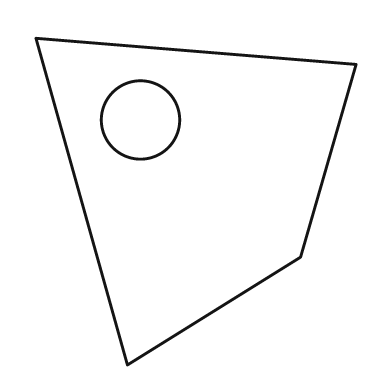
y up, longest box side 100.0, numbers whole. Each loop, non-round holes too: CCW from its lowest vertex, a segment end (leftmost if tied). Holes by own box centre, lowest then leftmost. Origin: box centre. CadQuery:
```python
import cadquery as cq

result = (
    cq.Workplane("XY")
    .moveTo(-21.0, -50.0)
    .lineTo(32.0, -17.0)
    .lineTo(49.0, 42.0)
    .lineTo(-49.0, 50.0)
    .close()
    .moveTo(-17.0, 25.0)
    .circle(12.0)
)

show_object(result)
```